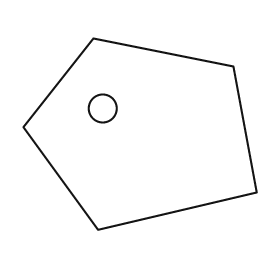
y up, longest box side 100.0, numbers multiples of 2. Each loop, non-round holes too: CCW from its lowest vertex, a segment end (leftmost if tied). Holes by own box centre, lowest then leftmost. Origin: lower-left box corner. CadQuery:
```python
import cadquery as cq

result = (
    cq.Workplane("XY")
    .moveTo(32.0, 0.0)
    .lineTo(100.0, 16.0)
    .lineTo(90.0, 70.0)
    .lineTo(30.0, 82.0)
    .lineTo(0.0, 44.0)
    .close()
    .moveTo(34.0, 52.0)
    .circle(6.0)
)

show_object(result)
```